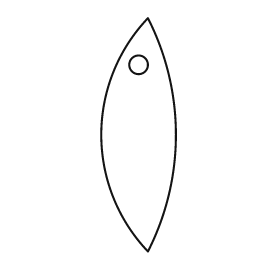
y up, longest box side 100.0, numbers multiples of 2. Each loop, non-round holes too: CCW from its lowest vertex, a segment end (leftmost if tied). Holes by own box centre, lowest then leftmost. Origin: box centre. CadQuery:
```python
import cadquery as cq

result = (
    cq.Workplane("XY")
    .moveTo(4.0, -50.0)
    .threePointArc((16.0, 0.0), (4.0, 50.0))
    .threePointArc((-16.0, 0.0), (4.0, -50.0))
    .close()
    .moveTo(0.0, 30.0)
    .circle(4.0)
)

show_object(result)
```